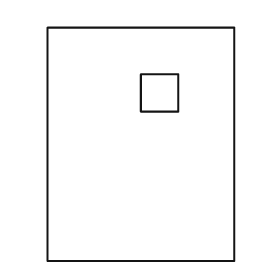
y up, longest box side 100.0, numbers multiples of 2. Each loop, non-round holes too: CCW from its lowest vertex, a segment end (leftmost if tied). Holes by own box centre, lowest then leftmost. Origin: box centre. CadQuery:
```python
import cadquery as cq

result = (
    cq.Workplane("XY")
    .moveTo(-40.0, -50.0)
    .lineTo(40.0, -50.0)
    .lineTo(40.0, 50.0)
    .lineTo(-40.0, 50.0)
    .close()
    .moveTo(0.0, 14.0)
    .lineTo(16.0, 14.0)
    .lineTo(16.0, 30.0)
    .lineTo(0.0, 30.0)
    .close()
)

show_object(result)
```